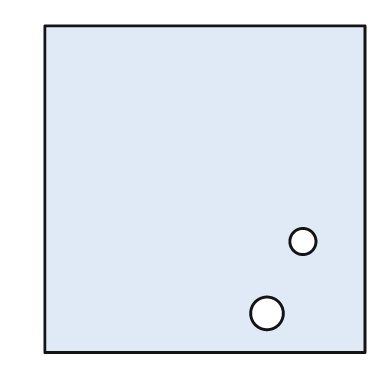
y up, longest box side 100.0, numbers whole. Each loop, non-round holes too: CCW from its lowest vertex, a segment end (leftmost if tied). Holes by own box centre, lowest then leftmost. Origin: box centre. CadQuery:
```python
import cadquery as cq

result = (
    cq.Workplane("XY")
    .moveTo(-49.0, -50.0)
    .lineTo(49.0, -50.0)
    .lineTo(49.0, 50.0)
    .lineTo(-49.0, 50.0)
    .close()
    .moveTo(19.0, -38.0)
    .circle(5.0)
    .moveTo(30.0, -16.0)
    .circle(4.0)
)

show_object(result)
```